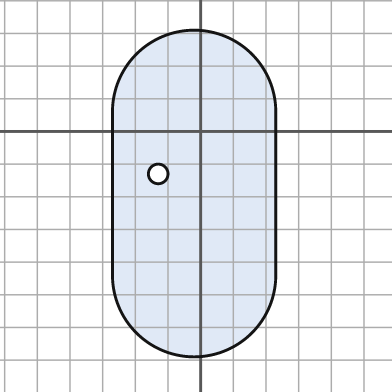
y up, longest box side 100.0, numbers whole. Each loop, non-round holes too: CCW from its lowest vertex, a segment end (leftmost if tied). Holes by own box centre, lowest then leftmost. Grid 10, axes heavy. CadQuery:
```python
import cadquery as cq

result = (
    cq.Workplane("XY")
    .moveTo(-27.0, -44.0)
    .threePointArc((-2.0, -69.0), (23.0, -44.0))
    .lineTo(23.0, 6.0)
    .threePointArc((-2.0, 31.0), (-27.0, 6.0))
    .close()
    .moveTo(-13.0, -13.0)
    .circle(3.0)
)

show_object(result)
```